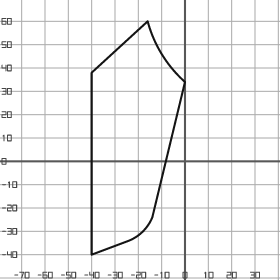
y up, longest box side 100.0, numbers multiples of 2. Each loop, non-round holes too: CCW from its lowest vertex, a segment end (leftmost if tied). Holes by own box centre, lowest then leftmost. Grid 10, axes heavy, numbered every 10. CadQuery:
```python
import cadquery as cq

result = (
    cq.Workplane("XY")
    .moveTo(-40.0, -40.0)
    .lineTo(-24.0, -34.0)
    .threePointArc((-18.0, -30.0), (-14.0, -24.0))
    .lineTo(0.0, 34.0)
    .threePointArc((-10.0, 46.0), (-16.0, 60.0))
    .lineTo(-40.0, 38.0)
    .close()
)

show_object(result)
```